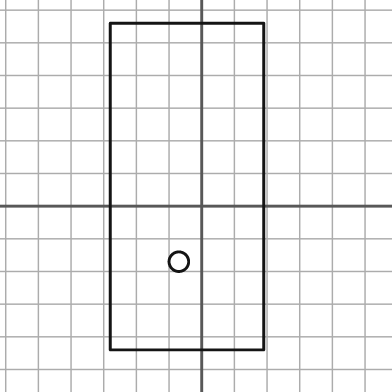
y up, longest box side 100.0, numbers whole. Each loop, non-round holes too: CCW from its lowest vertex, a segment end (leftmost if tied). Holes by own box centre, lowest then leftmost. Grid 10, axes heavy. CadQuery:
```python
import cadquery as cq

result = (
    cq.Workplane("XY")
    .moveTo(-28.0, -44.0)
    .lineTo(19.0, -44.0)
    .lineTo(19.0, 56.0)
    .lineTo(-28.0, 56.0)
    .close()
    .moveTo(-7.0, -17.0)
    .circle(3.0)
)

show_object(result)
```